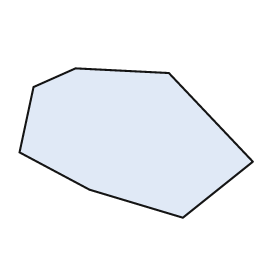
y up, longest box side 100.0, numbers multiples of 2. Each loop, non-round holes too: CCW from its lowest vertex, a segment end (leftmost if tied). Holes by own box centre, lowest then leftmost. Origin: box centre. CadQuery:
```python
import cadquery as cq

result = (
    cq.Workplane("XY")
    .moveTo(20.0, -32.0)
    .lineTo(50.0, -8.0)
    .lineTo(14.0, 30.0)
    .lineTo(-26.0, 32.0)
    .lineTo(-44.0, 24.0)
    .lineTo(-50.0, -4.0)
    .lineTo(-20.0, -20.0)
    .close()
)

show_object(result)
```